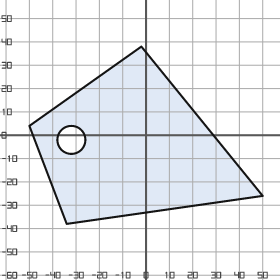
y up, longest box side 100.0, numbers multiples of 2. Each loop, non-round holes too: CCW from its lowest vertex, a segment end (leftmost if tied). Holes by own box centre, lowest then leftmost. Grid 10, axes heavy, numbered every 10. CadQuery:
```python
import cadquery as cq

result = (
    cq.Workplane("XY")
    .moveTo(-34.0, -38.0)
    .lineTo(50.0, -26.0)
    .lineTo(-2.0, 38.0)
    .lineTo(-50.0, 4.0)
    .close()
    .moveTo(-32.0, -2.0)
    .circle(6.0)
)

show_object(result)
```